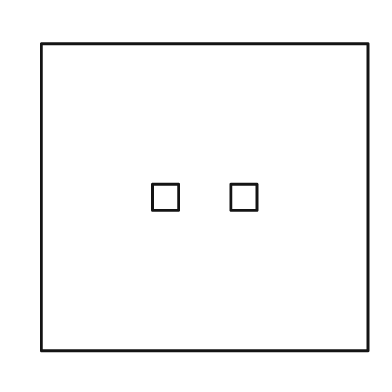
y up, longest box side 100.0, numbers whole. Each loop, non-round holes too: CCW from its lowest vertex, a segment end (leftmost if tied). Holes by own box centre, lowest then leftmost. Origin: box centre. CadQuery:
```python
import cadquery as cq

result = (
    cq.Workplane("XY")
    .moveTo(-50.0, -47.0)
    .lineTo(50.0, -47.0)
    .lineTo(50.0, 47.0)
    .lineTo(-50.0, 47.0)
    .close()
    .moveTo(-16.0, -4.0)
    .lineTo(-8.0, -4.0)
    .lineTo(-8.0, 4.0)
    .lineTo(-16.0, 4.0)
    .close()
    .moveTo(8.0, -4.0)
    .lineTo(16.0, -4.0)
    .lineTo(16.0, 4.0)
    .lineTo(8.0, 4.0)
    .close()
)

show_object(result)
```